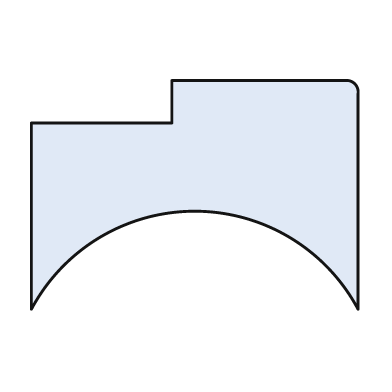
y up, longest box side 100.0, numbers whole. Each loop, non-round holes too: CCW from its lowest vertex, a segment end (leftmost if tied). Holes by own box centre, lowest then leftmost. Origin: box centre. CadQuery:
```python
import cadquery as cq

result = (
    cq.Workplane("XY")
    .moveTo(-50.0, -35.0)
    .threePointArc((0.0, -5.0), (50.0, -35.0))
    .lineTo(50.0, 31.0)
    .threePointArc((49.0, 34.0), (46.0, 35.0))
    .lineTo(-7.0, 35.0)
    .lineTo(-7.0, 22.0)
    .lineTo(-50.0, 22.0)
    .close()
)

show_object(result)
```